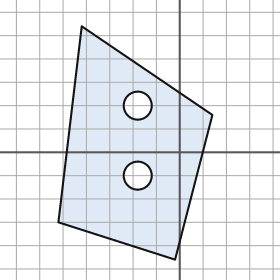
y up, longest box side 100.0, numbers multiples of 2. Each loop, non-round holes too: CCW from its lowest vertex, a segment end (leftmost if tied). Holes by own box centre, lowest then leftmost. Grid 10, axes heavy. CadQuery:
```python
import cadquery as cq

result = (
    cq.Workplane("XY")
    .moveTo(-2.0, -46.0)
    .lineTo(14.0, 16.0)
    .lineTo(-42.0, 54.0)
    .lineTo(-52.0, -30.0)
    .close()
    .moveTo(-18.0, -10.0)
    .circle(6.0)
    .moveTo(-18.0, 20.0)
    .circle(6.0)
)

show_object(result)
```